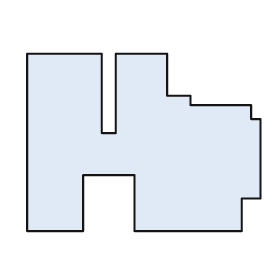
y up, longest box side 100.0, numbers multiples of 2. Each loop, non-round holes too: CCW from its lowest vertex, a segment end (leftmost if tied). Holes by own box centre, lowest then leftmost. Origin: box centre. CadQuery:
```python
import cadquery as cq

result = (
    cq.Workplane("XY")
    .moveTo(-50.0, -38.0)
    .lineTo(-26.0, -38.0)
    .lineTo(-26.0, -14.0)
    .lineTo(-4.0, -14.0)
    .lineTo(-4.0, -38.0)
    .lineTo(42.0, -38.0)
    .lineTo(42.0, -24.0)
    .lineTo(50.0, -24.0)
    .lineTo(50.0, 10.0)
    .lineTo(46.0, 10.0)
    .lineTo(46.0, 16.0)
    .lineTo(20.0, 16.0)
    .lineTo(20.0, 20.0)
    .lineTo(10.0, 20.0)
    .lineTo(10.0, 38.0)
    .lineTo(-12.0, 38.0)
    .lineTo(-12.0, 4.0)
    .lineTo(-18.0, 4.0)
    .lineTo(-18.0, 38.0)
    .lineTo(-50.0, 38.0)
    .close()
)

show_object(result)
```